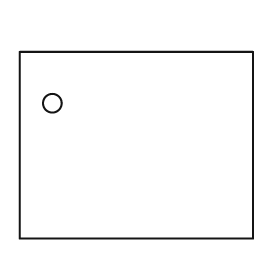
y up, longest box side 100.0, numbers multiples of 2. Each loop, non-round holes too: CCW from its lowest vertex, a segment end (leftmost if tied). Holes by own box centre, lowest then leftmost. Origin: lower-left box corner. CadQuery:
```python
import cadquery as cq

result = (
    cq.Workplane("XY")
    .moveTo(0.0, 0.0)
    .lineTo(100.0, 0.0)
    .lineTo(100.0, 80.0)
    .lineTo(0.0, 80.0)
    .close()
    .moveTo(14.0, 58.0)
    .circle(4.0)
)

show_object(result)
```